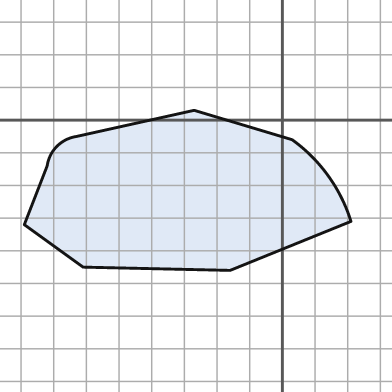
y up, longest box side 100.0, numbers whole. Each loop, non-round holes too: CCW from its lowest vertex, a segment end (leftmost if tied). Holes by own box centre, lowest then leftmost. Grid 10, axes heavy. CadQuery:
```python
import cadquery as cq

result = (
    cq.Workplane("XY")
    .moveTo(-16.0, -46.0)
    .lineTo(21.0, -31.0)
    .threePointArc((14.0, -17.0), (3.0, -6.0))
    .lineTo(-27.0, 3.0)
    .lineTo(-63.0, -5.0)
    .threePointArc((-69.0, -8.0), (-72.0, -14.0))
    .lineTo(-79.0, -32.0)
    .lineTo(-61.0, -45.0)
    .close()
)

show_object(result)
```